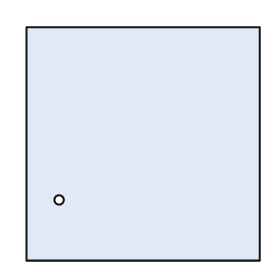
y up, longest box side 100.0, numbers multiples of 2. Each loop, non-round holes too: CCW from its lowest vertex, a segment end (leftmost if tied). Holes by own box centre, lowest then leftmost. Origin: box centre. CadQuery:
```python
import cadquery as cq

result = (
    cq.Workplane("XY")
    .moveTo(-50.0, -50.0)
    .lineTo(50.0, -50.0)
    .lineTo(50.0, 50.0)
    .lineTo(-50.0, 50.0)
    .close()
    .moveTo(-36.0, -24.0)
    .circle(2.0)
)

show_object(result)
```